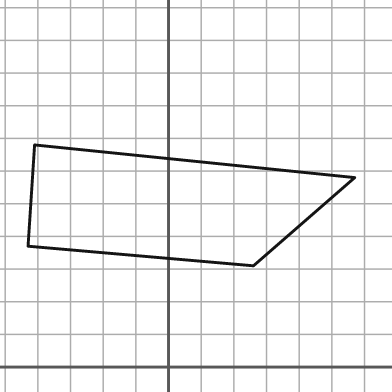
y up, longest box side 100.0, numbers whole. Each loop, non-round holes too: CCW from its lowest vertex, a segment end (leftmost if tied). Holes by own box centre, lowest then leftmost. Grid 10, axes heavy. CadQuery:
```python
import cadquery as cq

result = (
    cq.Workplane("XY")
    .moveTo(26.0, 31.0)
    .lineTo(57.0, 58.0)
    .lineTo(-41.0, 68.0)
    .lineTo(-43.0, 37.0)
    .close()
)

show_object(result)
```